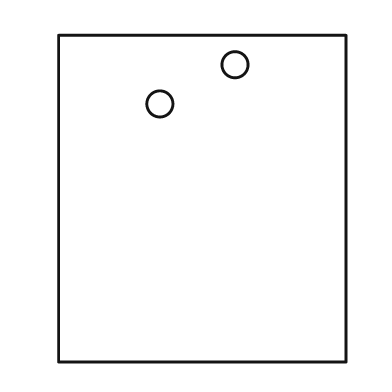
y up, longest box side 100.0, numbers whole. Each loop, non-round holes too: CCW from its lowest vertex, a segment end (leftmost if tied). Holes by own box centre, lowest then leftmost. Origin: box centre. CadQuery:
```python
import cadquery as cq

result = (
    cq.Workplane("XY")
    .moveTo(-44.0, -50.0)
    .lineTo(44.0, -50.0)
    .lineTo(44.0, 50.0)
    .lineTo(-44.0, 50.0)
    .close()
    .moveTo(-13.0, 29.0)
    .circle(4.0)
    .moveTo(10.0, 41.0)
    .circle(4.0)
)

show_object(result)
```